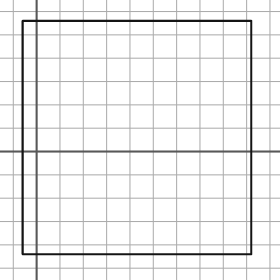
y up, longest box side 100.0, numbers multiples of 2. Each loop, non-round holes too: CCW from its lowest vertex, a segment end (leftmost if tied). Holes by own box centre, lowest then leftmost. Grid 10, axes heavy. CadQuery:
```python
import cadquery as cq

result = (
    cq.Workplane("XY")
    .moveTo(-6.0, -44.0)
    .lineTo(92.0, -44.0)
    .lineTo(92.0, 56.0)
    .lineTo(-6.0, 56.0)
    .close()
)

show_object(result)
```